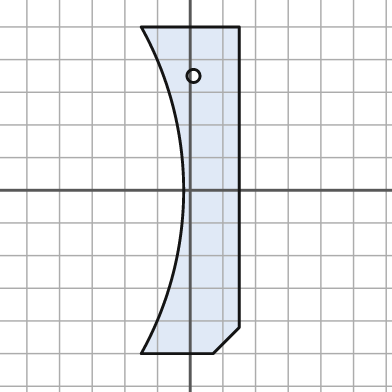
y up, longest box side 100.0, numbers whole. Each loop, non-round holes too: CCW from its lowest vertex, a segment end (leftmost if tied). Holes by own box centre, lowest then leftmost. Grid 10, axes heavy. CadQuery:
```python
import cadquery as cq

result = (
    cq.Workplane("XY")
    .moveTo(-15.0, -50.0)
    .lineTo(7.0, -50.0)
    .lineTo(15.0, -42.0)
    .lineTo(15.0, 50.0)
    .lineTo(-15.0, 50.0)
    .threePointArc((-2.0, 0.0), (-15.0, -50.0))
    .close()
    .moveTo(1.0, 35.0)
    .circle(2.0)
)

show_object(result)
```